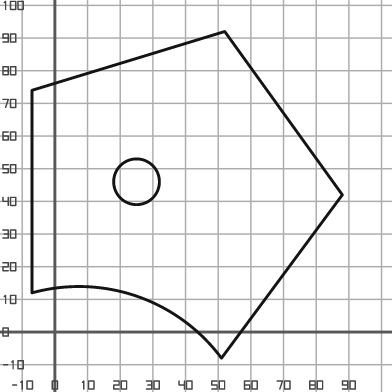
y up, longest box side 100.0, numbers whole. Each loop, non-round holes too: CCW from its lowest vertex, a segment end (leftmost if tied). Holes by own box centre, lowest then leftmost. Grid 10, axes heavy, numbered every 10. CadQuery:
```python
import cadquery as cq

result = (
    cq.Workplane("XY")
    .moveTo(51.0, -8.0)
    .lineTo(88.0, 42.0)
    .lineTo(52.0, 92.0)
    .lineTo(-7.0, 74.0)
    .lineTo(-7.0, 12.0)
    .threePointArc((25.0, 11.0), (51.0, -8.0))
    .close()
    .moveTo(25.0, 46.0)
    .circle(7.0)
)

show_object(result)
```